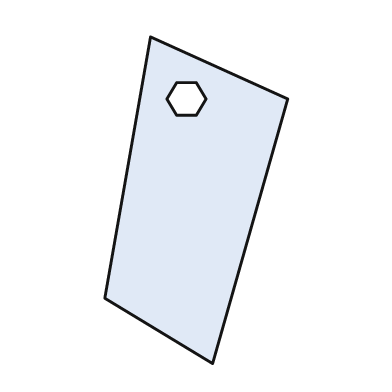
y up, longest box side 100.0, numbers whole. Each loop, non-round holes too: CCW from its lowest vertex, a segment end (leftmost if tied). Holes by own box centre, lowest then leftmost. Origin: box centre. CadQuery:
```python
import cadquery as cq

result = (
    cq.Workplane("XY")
    .moveTo(5.0, -50.0)
    .lineTo(28.0, 31.0)
    .lineTo(-14.0, 50.0)
    .lineTo(-28.0, -30.0)
    .close()
    .moveTo(-6.0, 26.0)
    .lineTo(0.0, 26.0)
    .lineTo(3.0, 31.0)
    .lineTo(0.0, 36.0)
    .lineTo(-6.0, 36.0)
    .lineTo(-9.0, 31.0)
    .close()
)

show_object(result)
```